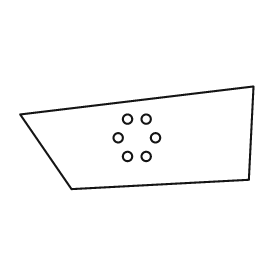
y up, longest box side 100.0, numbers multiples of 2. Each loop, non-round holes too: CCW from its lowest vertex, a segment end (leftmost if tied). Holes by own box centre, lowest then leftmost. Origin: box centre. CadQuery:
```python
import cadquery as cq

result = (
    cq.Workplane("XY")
    .moveTo(-28.0, -22.0)
    .lineTo(48.0, -18.0)
    .lineTo(50.0, 22.0)
    .lineTo(-50.0, 10.0)
    .close()
    .moveTo(-4.0, -8.0)
    .circle(2.0)
    .moveTo(4.0, -8.0)
    .circle(2.0)
    .moveTo(-8.0, 0.0)
    .circle(2.0)
    .moveTo(8.0, 0.0)
    .circle(2.0)
    .moveTo(-4.0, 8.0)
    .circle(2.0)
    .moveTo(4.0, 8.0)
    .circle(2.0)
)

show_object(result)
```